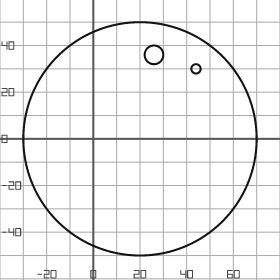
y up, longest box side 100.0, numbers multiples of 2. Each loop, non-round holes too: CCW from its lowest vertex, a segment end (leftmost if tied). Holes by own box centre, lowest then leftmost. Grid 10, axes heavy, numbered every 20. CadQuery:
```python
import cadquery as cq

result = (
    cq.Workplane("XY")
    .moveTo(20.0, 0.0)
    .circle(50.0)
    .moveTo(44.0, 30.0)
    .circle(2.0)
    .moveTo(26.0, 36.0)
    .circle(4.0)
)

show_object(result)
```